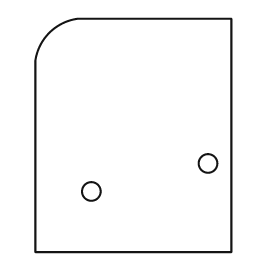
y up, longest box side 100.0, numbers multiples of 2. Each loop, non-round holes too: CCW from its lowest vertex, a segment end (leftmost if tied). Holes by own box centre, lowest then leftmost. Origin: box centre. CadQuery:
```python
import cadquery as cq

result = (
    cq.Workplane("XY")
    .moveTo(-42.0, -50.0)
    .lineTo(42.0, -50.0)
    .lineTo(42.0, 50.0)
    .lineTo(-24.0, 50.0)
    .threePointArc((-36.0, 44.0), (-42.0, 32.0))
    .close()
    .moveTo(-18.0, -24.0)
    .circle(4.0)
    .moveTo(32.0, -12.0)
    .circle(4.0)
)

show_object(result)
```